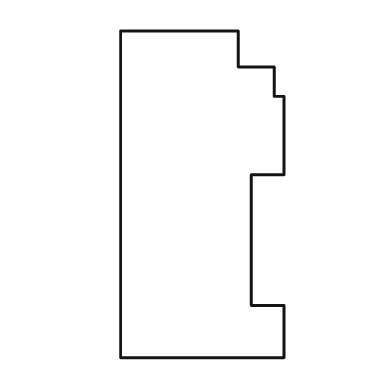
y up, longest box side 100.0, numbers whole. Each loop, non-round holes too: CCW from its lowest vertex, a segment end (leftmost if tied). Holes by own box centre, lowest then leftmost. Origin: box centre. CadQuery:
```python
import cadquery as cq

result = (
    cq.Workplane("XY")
    .moveTo(-25.0, -50.0)
    .lineTo(25.0, -50.0)
    .lineTo(25.0, -34.0)
    .lineTo(15.0, -34.0)
    .lineTo(15.0, 6.0)
    .lineTo(25.0, 6.0)
    .lineTo(25.0, 30.0)
    .lineTo(22.0, 30.0)
    .lineTo(22.0, 39.0)
    .lineTo(11.0, 39.0)
    .lineTo(11.0, 50.0)
    .lineTo(-25.0, 50.0)
    .close()
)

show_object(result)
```